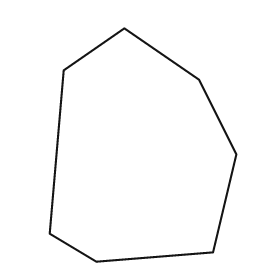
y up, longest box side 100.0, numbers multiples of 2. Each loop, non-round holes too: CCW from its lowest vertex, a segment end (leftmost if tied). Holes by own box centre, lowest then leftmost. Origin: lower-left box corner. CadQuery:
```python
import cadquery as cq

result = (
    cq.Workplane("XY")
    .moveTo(20.0, 0.0)
    .lineTo(70.0, 4.0)
    .lineTo(80.0, 46.0)
    .lineTo(64.0, 78.0)
    .lineTo(32.0, 100.0)
    .lineTo(6.0, 82.0)
    .lineTo(0.0, 12.0)
    .close()
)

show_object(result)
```